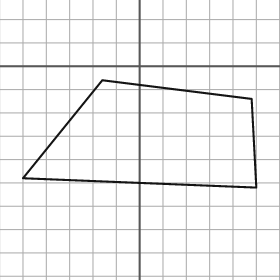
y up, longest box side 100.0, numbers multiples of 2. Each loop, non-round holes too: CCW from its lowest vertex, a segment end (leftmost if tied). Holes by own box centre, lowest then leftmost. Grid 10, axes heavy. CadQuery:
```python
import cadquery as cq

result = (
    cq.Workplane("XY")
    .moveTo(50.0, -52.0)
    .lineTo(48.0, -14.0)
    .lineTo(-16.0, -6.0)
    .lineTo(-50.0, -48.0)
    .close()
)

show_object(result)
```